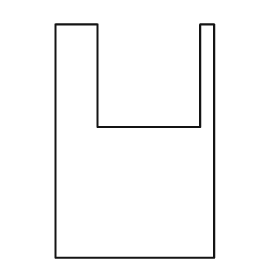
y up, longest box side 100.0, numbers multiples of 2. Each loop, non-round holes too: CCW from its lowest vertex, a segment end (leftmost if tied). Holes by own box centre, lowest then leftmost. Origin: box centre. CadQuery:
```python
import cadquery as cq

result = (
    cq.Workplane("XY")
    .moveTo(-34.0, -50.0)
    .lineTo(34.0, -50.0)
    .lineTo(34.0, 50.0)
    .lineTo(28.0, 50.0)
    .lineTo(28.0, 6.0)
    .lineTo(-16.0, 6.0)
    .lineTo(-16.0, 50.0)
    .lineTo(-34.0, 50.0)
    .close()
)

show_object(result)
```